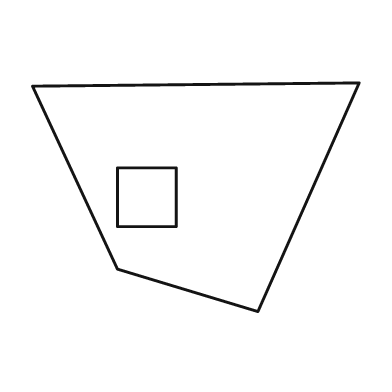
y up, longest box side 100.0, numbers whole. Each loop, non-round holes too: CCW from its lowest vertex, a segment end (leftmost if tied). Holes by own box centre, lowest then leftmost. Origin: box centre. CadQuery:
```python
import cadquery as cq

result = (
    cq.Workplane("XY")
    .moveTo(19.0, -35.0)
    .lineTo(50.0, 35.0)
    .lineTo(-50.0, 34.0)
    .lineTo(-24.0, -22.0)
    .close()
    .moveTo(-24.0, -9.0)
    .lineTo(-6.0, -9.0)
    .lineTo(-6.0, 9.0)
    .lineTo(-24.0, 9.0)
    .close()
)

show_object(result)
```